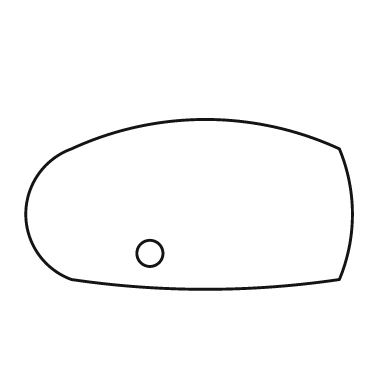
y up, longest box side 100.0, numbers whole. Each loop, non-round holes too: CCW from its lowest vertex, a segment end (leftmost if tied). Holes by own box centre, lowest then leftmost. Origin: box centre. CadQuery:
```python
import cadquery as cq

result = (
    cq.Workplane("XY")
    .moveTo(-36.0, -23.0)
    .threePointArc((5.0, -26.0), (46.0, -23.0))
    .threePointArc((50.0, -3.0), (46.0, 17.0))
    .threePointArc((5.0, 26.0), (-36.0, 17.0))
    .threePointArc((-50.0, -3.0), (-36.0, -23.0))
    .close()
    .moveTo(-12.0, -15.0)
    .circle(4.0)
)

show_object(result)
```